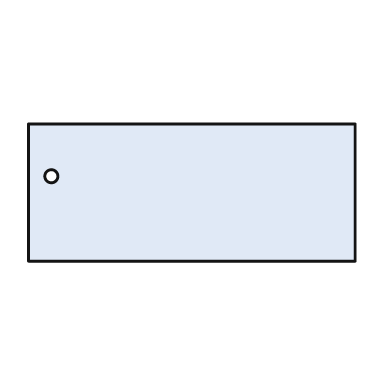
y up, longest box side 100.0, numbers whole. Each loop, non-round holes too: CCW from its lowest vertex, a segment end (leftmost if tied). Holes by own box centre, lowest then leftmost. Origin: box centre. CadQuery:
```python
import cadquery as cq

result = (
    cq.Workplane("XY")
    .moveTo(-50.0, -21.0)
    .lineTo(50.0, -21.0)
    .lineTo(50.0, 21.0)
    .lineTo(-50.0, 21.0)
    .close()
    .moveTo(-43.0, 5.0)
    .circle(2.0)
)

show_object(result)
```